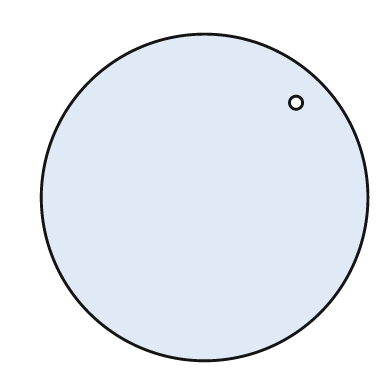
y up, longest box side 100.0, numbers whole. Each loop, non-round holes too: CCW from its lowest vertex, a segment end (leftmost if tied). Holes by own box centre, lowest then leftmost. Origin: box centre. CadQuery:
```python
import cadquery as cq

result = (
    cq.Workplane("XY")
    .moveTo(0.0, 0.0)
    .circle(50.0)
    .moveTo(28.0, 29.0)
    .circle(2.0)
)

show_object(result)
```